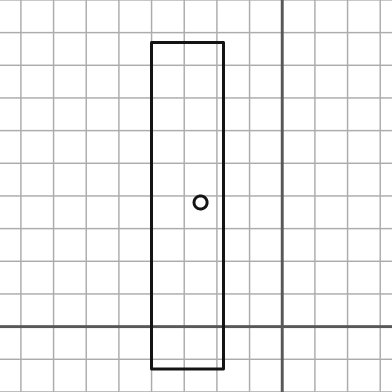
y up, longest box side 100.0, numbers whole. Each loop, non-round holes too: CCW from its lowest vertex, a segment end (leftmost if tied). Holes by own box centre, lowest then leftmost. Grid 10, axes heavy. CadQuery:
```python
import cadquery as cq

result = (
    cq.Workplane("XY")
    .moveTo(-40.0, -13.0)
    .lineTo(-18.0, -13.0)
    .lineTo(-18.0, 87.0)
    .lineTo(-40.0, 87.0)
    .close()
    .moveTo(-25.0, 38.0)
    .circle(2.0)
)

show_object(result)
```